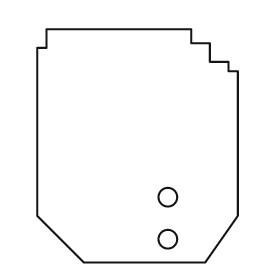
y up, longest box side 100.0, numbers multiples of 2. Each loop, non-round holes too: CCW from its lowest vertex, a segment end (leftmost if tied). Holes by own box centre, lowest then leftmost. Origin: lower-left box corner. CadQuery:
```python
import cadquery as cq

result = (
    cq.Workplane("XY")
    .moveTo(20.0, 0.0)
    .lineTo(72.0, 0.0)
    .lineTo(86.0, 20.0)
    .lineTo(86.0, 82.0)
    .lineTo(82.0, 82.0)
    .lineTo(82.0, 86.0)
    .lineTo(74.0, 86.0)
    .lineTo(74.0, 94.0)
    .lineTo(66.0, 94.0)
    .lineTo(66.0, 100.0)
    .lineTo(4.0, 100.0)
    .lineTo(4.0, 92.0)
    .lineTo(0.0, 92.0)
    .lineTo(0.0, 20.0)
    .close()
    .moveTo(56.0, 10.0)
    .circle(4.0)
    .moveTo(56.0, 28.0)
    .circle(4.0)
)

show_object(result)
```